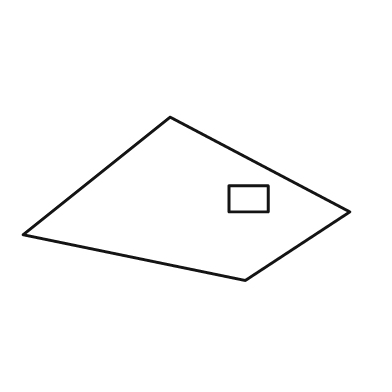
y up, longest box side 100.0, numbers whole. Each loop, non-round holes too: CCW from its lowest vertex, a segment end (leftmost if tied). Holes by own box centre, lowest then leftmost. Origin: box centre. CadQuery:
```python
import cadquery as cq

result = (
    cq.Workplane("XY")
    .moveTo(18.0, -25.0)
    .lineTo(50.0, -4.0)
    .lineTo(-5.0, 25.0)
    .lineTo(-50.0, -11.0)
    .close()
    .moveTo(13.0, -4.0)
    .lineTo(25.0, -4.0)
    .lineTo(25.0, 4.0)
    .lineTo(13.0, 4.0)
    .close()
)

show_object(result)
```